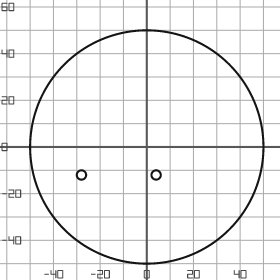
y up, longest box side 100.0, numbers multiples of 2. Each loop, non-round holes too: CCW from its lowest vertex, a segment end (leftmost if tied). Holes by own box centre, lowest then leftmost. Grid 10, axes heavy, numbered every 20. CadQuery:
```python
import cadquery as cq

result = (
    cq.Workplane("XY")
    .moveTo(0.0, 0.0)
    .circle(50.0)
    .moveTo(-28.0, -12.0)
    .circle(2.0)
    .moveTo(4.0, -12.0)
    .circle(2.0)
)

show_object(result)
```